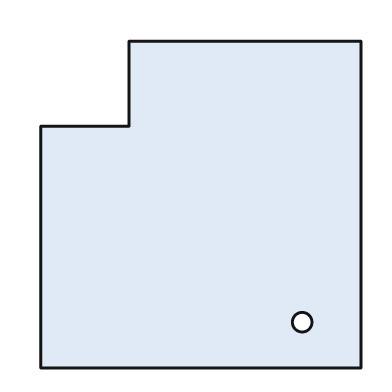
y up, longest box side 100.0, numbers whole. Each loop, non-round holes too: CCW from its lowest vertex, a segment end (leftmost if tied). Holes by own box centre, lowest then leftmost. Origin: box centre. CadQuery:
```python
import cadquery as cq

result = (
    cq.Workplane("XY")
    .moveTo(-49.0, -50.0)
    .lineTo(49.0, -50.0)
    .lineTo(49.0, 50.0)
    .lineTo(-22.0, 50.0)
    .lineTo(-22.0, 24.0)
    .lineTo(-49.0, 24.0)
    .close()
    .moveTo(31.0, -36.0)
    .circle(3.0)
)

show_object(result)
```